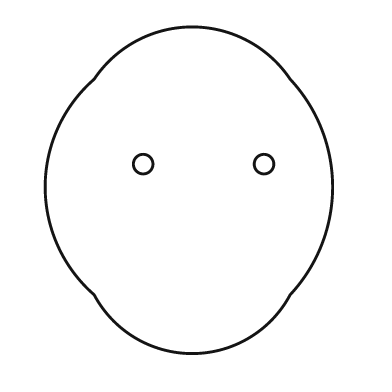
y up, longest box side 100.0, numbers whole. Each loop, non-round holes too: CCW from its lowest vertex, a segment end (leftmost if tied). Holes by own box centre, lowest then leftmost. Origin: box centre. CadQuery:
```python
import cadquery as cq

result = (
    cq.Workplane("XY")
    .moveTo(-29.0, -32.0)
    .threePointArc((1.0, -50.0), (31.0, -32.0))
    .threePointArc((44.0, 1.0), (31.0, 34.0))
    .threePointArc((1.0, 50.0), (-29.0, 34.0))
    .threePointArc((-44.0, 1.0), (-29.0, -32.0))
    .close()
    .moveTo(-14.0, 8.0)
    .circle(3.0)
    .moveTo(23.0, 8.0)
    .circle(3.0)
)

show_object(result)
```